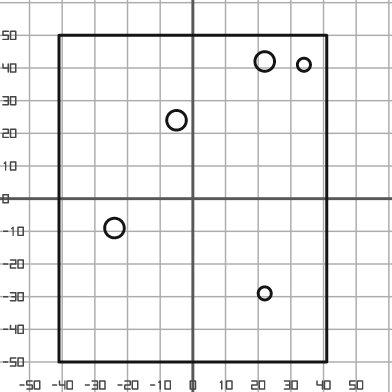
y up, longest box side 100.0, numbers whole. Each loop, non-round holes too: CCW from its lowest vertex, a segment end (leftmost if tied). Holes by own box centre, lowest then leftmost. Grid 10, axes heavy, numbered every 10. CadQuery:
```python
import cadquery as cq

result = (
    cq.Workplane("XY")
    .moveTo(-41.0, -50.0)
    .lineTo(41.0, -50.0)
    .lineTo(41.0, 50.0)
    .lineTo(-41.0, 50.0)
    .close()
    .moveTo(22.0, -29.0)
    .circle(2.0)
    .moveTo(-24.0, -9.0)
    .circle(3.0)
    .moveTo(-5.0, 24.0)
    .circle(3.0)
    .moveTo(34.0, 41.0)
    .circle(2.0)
    .moveTo(22.0, 42.0)
    .circle(3.0)
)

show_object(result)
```